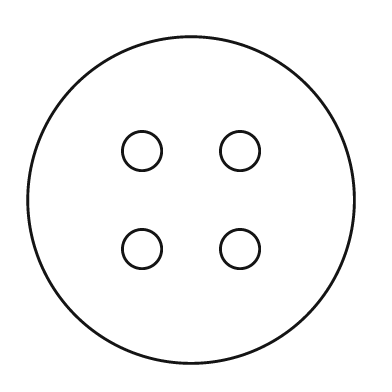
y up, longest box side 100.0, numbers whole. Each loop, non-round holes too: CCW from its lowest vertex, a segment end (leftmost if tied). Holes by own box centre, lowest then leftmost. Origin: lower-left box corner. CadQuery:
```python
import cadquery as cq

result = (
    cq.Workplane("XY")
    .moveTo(50.0, 50.0)
    .circle(50.0)
    .moveTo(35.0, 35.0)
    .circle(6.0)
    .moveTo(65.0, 35.0)
    .circle(6.0)
    .moveTo(35.0, 65.0)
    .circle(6.0)
    .moveTo(65.0, 65.0)
    .circle(6.0)
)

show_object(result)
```